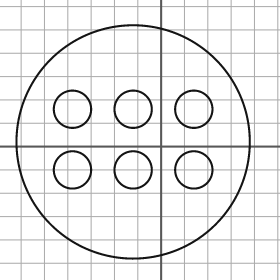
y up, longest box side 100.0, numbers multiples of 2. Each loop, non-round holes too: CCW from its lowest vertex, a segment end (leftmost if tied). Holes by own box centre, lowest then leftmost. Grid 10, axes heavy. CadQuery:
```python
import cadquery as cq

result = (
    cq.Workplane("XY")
    .moveTo(-12.0, 2.0)
    .circle(50.0)
    .moveTo(-38.0, -10.0)
    .circle(8.0)
    .moveTo(-12.0, -10.0)
    .circle(8.0)
    .moveTo(14.0, -10.0)
    .circle(8.0)
    .moveTo(-38.0, 16.0)
    .circle(8.0)
    .moveTo(-12.0, 16.0)
    .circle(8.0)
    .moveTo(14.0, 16.0)
    .circle(8.0)
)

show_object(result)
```